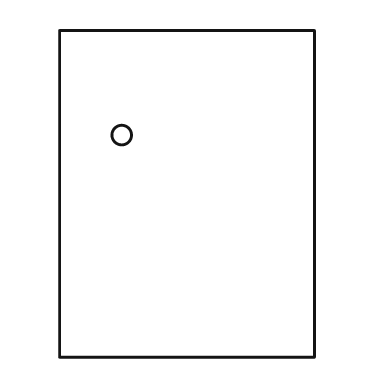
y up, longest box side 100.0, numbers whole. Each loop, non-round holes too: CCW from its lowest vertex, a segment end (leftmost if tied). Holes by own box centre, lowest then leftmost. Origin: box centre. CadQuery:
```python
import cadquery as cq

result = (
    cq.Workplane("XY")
    .moveTo(-39.0, -50.0)
    .lineTo(39.0, -50.0)
    .lineTo(39.0, 50.0)
    .lineTo(-39.0, 50.0)
    .close()
    .moveTo(-20.0, 18.0)
    .circle(3.0)
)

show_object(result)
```